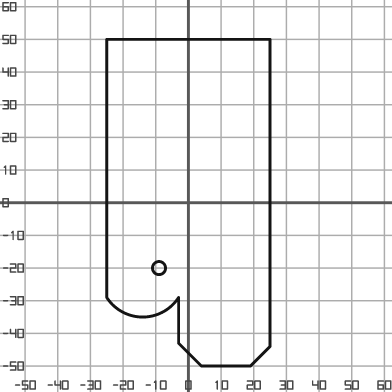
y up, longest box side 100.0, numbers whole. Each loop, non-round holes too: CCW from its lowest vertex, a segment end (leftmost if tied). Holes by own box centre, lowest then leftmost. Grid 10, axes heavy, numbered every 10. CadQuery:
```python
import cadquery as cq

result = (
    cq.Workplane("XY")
    .moveTo(4.0, -50.0)
    .lineTo(19.0, -50.0)
    .lineTo(25.0, -44.0)
    .lineTo(25.0, 50.0)
    .lineTo(-25.0, 50.0)
    .lineTo(-25.0, -29.0)
    .threePointArc((-14.0, -35.0), (-3.0, -29.0))
    .lineTo(-3.0, -43.0)
    .close()
    .moveTo(-9.0, -20.0)
    .circle(2.0)
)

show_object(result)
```